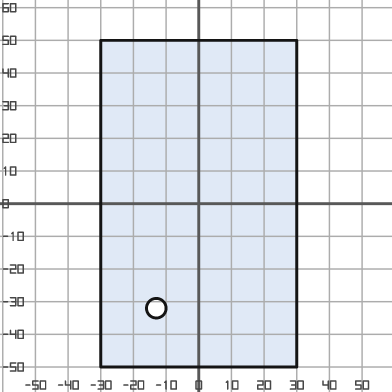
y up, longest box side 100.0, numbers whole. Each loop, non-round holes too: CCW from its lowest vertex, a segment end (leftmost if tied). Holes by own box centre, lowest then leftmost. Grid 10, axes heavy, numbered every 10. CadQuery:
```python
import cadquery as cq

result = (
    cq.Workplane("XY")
    .moveTo(-30.0, -50.0)
    .lineTo(30.0, -50.0)
    .lineTo(30.0, 50.0)
    .lineTo(-30.0, 50.0)
    .close()
    .moveTo(-13.0, -32.0)
    .circle(3.0)
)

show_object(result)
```